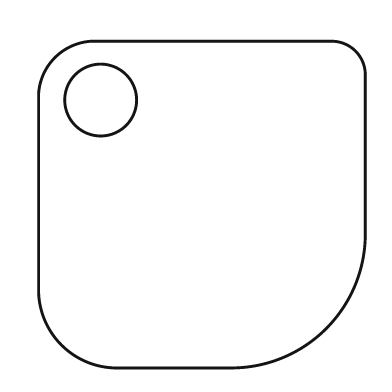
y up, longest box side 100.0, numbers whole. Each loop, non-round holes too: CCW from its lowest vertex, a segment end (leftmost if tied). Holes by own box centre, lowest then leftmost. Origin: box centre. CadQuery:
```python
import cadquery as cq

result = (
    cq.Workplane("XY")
    .moveTo(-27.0, -50.0)
    .lineTo(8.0, -50.0)
    .threePointArc((38.0, -38.0), (50.0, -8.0))
    .lineTo(50.0, 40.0)
    .threePointArc((47.0, 47.0), (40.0, 50.0))
    .lineTo(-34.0, 50.0)
    .threePointArc((-45.0, 45.0), (-50.0, 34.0))
    .lineTo(-50.0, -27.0)
    .threePointArc((-43.0, -43.0), (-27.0, -50.0))
    .close()
    .moveTo(-31.0, 32.0)
    .circle(11.0)
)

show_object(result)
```